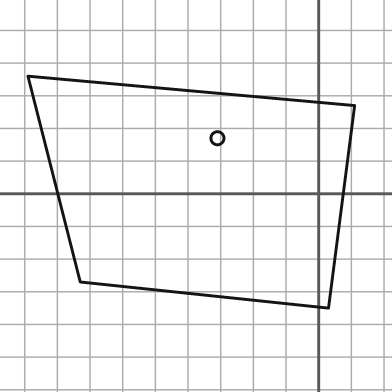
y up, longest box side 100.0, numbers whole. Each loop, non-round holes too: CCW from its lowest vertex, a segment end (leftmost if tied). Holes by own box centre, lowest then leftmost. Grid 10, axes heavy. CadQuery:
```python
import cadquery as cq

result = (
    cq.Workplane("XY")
    .moveTo(3.0, -35.0)
    .lineTo(11.0, 27.0)
    .lineTo(-89.0, 36.0)
    .lineTo(-73.0, -27.0)
    .close()
    .moveTo(-31.0, 17.0)
    .circle(2.0)
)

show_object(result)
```